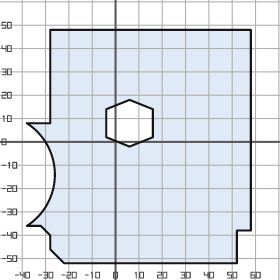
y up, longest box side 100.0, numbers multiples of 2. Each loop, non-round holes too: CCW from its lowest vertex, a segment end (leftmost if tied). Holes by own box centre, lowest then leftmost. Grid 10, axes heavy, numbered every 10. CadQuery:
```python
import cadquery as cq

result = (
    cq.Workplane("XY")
    .moveTo(-22.0, -52.0)
    .lineTo(52.0, -52.0)
    .lineTo(52.0, -38.0)
    .lineTo(58.0, -38.0)
    .lineTo(58.0, 48.0)
    .lineTo(-28.0, 48.0)
    .lineTo(-28.0, 8.0)
    .lineTo(-38.0, 8.0)
    .threePointArc((-26.0, -14.0), (-38.0, -36.0))
    .lineTo(-32.0, -36.0)
    .lineTo(-28.0, -40.0)
    .lineTo(-28.0, -46.0)
    .close()
    .moveTo(6.0, -2.0)
    .lineTo(16.0, 2.0)
    .lineTo(16.0, 14.0)
    .lineTo(6.0, 18.0)
    .lineTo(-4.0, 14.0)
    .lineTo(-4.0, 2.0)
    .close()
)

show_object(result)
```